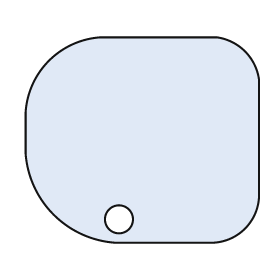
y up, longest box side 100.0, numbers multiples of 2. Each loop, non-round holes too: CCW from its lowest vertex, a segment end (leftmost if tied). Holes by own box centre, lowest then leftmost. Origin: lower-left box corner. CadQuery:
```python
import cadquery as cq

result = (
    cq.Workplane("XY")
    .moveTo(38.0, 0.0)
    .lineTo(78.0, 0.0)
    .threePointArc((94.0, 6.0), (100.0, 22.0))
    .lineTo(100.0, 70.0)
    .threePointArc((94.0, 82.0), (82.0, 88.0))
    .lineTo(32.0, 88.0)
    .threePointArc((10.0, 78.0), (0.0, 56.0))
    .lineTo(0.0, 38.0)
    .threePointArc((12.0, 12.0), (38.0, 0.0))
    .close()
    .moveTo(40.0, 10.0)
    .circle(6.0)
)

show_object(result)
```